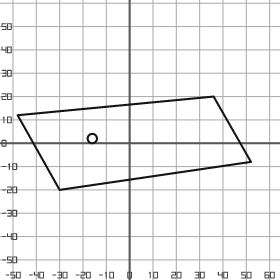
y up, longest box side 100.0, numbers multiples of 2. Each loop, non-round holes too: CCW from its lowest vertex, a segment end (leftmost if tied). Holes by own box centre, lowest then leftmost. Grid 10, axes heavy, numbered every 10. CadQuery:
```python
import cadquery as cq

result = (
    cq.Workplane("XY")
    .moveTo(-30.0, -20.0)
    .lineTo(52.0, -8.0)
    .lineTo(36.0, 20.0)
    .lineTo(-48.0, 12.0)
    .close()
    .moveTo(-16.0, 2.0)
    .circle(2.0)
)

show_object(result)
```